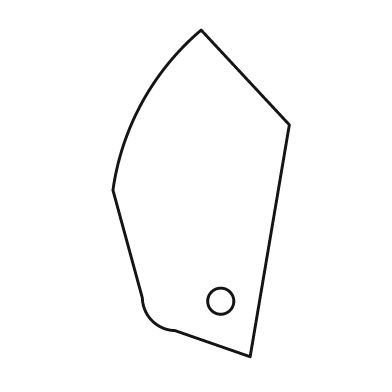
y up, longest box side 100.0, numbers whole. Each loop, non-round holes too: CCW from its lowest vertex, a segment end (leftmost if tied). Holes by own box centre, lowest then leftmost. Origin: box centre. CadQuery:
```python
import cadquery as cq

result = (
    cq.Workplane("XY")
    .moveTo(15.0, -50.0)
    .lineTo(27.0, 21.0)
    .lineTo(0.0, 50.0)
    .threePointArc((-18.0, 28.0), (-27.0, 1.0))
    .lineTo(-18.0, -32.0)
    .threePointArc((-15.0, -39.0), (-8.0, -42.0))
    .close()
    .moveTo(6.0, -33.0)
    .circle(4.0)
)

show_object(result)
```